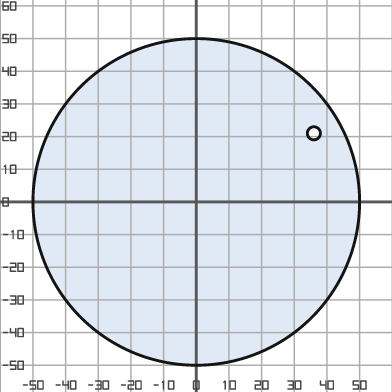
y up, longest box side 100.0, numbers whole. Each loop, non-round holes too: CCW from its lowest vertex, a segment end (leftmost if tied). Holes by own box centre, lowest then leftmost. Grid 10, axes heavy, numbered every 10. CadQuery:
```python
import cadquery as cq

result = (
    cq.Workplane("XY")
    .moveTo(0.0, 0.0)
    .circle(50.0)
    .moveTo(36.0, 21.0)
    .circle(2.0)
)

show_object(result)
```